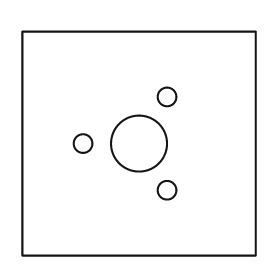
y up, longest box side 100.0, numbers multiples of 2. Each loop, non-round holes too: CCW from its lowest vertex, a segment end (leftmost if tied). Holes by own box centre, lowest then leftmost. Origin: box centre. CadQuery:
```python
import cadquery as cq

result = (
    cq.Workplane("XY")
    .moveTo(-50.0, -48.0)
    .lineTo(50.0, -48.0)
    .lineTo(50.0, 48.0)
    .lineTo(-50.0, 48.0)
    .close()
    .moveTo(12.0, -20.0)
    .circle(4.0)
    .moveTo(-24.0, 0.0)
    .circle(4.0)
    .moveTo(0.0, 0.0)
    .circle(12.0)
    .moveTo(12.0, 20.0)
    .circle(4.0)
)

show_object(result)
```